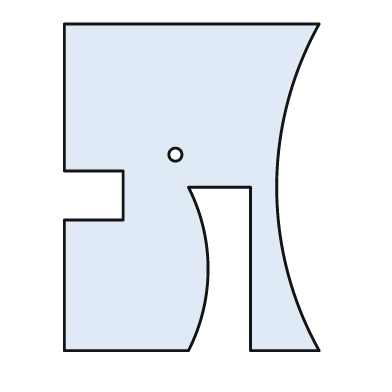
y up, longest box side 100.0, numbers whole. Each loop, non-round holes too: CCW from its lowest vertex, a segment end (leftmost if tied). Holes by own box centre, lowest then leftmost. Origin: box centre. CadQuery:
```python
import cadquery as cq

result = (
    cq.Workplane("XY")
    .moveTo(-39.0, -50.0)
    .lineTo(-1.0, -50.0)
    .threePointArc((5.0, -25.0), (-1.0, 0.0))
    .lineTo(18.0, 0.0)
    .lineTo(18.0, -50.0)
    .lineTo(39.0, -50.0)
    .threePointArc((26.0, 0.0), (39.0, 50.0))
    .lineTo(-39.0, 50.0)
    .lineTo(-39.0, 5.0)
    .lineTo(-21.0, 5.0)
    .lineTo(-21.0, -10.0)
    .lineTo(-39.0, -10.0)
    .close()
    .moveTo(-5.0, 10.0)
    .circle(2.0)
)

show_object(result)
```